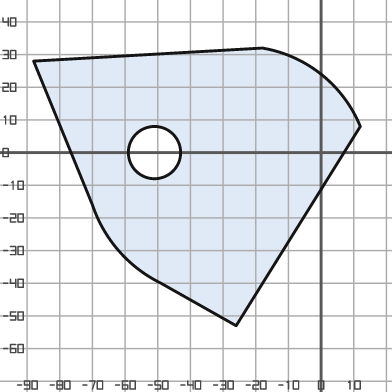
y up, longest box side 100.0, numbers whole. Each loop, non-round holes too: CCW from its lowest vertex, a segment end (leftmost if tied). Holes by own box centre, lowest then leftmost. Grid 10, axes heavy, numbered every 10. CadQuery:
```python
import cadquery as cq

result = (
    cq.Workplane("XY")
    .moveTo(-26.0, -53.0)
    .lineTo(12.0, 8.0)
    .threePointArc((0.0, 24.0), (-18.0, 32.0))
    .lineTo(-88.0, 28.0)
    .lineTo(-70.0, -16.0)
    .threePointArc((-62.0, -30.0), (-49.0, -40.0))
    .close()
    .moveTo(-51.0, 0.0)
    .circle(8.0)
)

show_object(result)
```